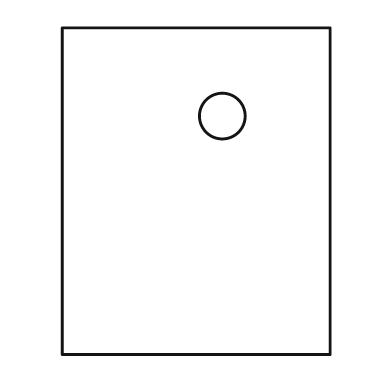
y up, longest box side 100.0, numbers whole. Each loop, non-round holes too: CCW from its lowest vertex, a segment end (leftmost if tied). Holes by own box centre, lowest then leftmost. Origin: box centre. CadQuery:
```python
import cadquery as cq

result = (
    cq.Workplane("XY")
    .moveTo(-41.0, -50.0)
    .lineTo(41.0, -50.0)
    .lineTo(41.0, 50.0)
    .lineTo(-41.0, 50.0)
    .close()
    .moveTo(8.0, 23.0)
    .circle(7.0)
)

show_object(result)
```